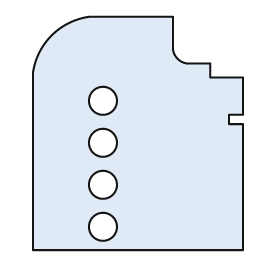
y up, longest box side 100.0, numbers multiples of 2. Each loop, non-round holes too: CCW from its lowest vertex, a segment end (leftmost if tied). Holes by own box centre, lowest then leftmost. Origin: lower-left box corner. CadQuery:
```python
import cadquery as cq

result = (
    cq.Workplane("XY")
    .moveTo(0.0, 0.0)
    .lineTo(90.0, 0.0)
    .lineTo(90.0, 54.0)
    .lineTo(84.0, 54.0)
    .lineTo(84.0, 58.0)
    .lineTo(90.0, 58.0)
    .lineTo(90.0, 74.0)
    .lineTo(76.0, 74.0)
    .lineTo(76.0, 80.0)
    .lineTo(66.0, 80.0)
    .threePointArc((62.0, 82.0), (60.0, 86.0))
    .lineTo(60.0, 100.0)
    .lineTo(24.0, 100.0)
    .threePointArc((8.0, 92.0), (0.0, 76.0))
    .close()
    .moveTo(30.0, 10.0)
    .circle(6.0)
    .moveTo(30.0, 28.0)
    .circle(6.0)
    .moveTo(30.0, 46.0)
    .circle(6.0)
    .moveTo(30.0, 64.0)
    .circle(6.0)
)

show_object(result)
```